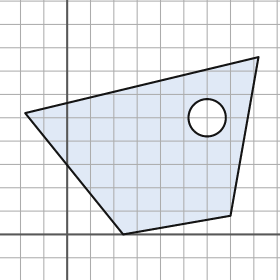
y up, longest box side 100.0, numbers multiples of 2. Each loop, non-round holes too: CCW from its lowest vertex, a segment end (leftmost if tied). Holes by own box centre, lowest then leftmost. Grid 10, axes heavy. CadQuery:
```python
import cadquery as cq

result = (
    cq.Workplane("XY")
    .moveTo(24.0, 0.0)
    .lineTo(70.0, 8.0)
    .lineTo(82.0, 76.0)
    .lineTo(-18.0, 52.0)
    .close()
    .moveTo(60.0, 50.0)
    .circle(8.0)
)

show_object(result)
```